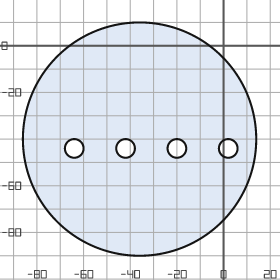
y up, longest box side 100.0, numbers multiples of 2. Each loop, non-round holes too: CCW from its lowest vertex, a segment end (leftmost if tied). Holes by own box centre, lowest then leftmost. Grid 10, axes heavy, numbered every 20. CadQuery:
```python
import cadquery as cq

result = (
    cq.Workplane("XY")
    .moveTo(-36.0, -40.0)
    .circle(50.0)
    .moveTo(-64.0, -44.0)
    .circle(4.0)
    .moveTo(-42.0, -44.0)
    .circle(4.0)
    .moveTo(-20.0, -44.0)
    .circle(4.0)
    .moveTo(2.0, -44.0)
    .circle(4.0)
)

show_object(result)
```